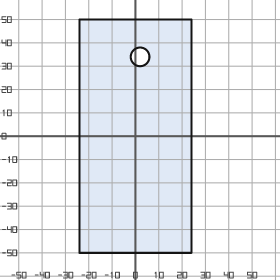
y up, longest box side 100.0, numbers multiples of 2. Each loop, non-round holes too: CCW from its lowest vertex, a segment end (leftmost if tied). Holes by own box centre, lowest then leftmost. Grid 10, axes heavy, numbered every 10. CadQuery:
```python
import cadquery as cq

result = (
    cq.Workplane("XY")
    .moveTo(-24.0, -50.0)
    .lineTo(24.0, -50.0)
    .lineTo(24.0, 50.0)
    .lineTo(-24.0, 50.0)
    .close()
    .moveTo(2.0, 34.0)
    .circle(4.0)
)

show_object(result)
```